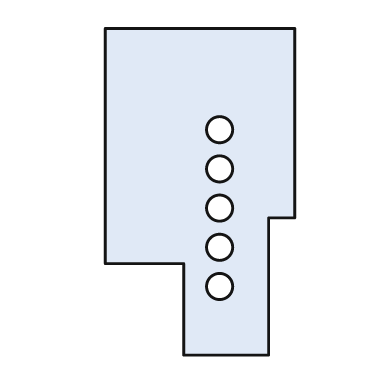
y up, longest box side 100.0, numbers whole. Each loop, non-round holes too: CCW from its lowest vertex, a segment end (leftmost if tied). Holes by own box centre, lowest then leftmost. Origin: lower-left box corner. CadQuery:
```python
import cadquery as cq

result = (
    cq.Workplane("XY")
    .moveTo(24.0, 0.0)
    .lineTo(50.0, 0.0)
    .lineTo(50.0, 42.0)
    .lineTo(58.0, 42.0)
    .lineTo(58.0, 100.0)
    .lineTo(0.0, 100.0)
    .lineTo(0.0, 28.0)
    .lineTo(24.0, 28.0)
    .close()
    .moveTo(35.0, 21.0)
    .circle(4.0)
    .moveTo(35.0, 33.0)
    .circle(4.0)
    .moveTo(35.0, 45.0)
    .circle(4.0)
    .moveTo(35.0, 57.0)
    .circle(4.0)
    .moveTo(35.0, 69.0)
    .circle(4.0)
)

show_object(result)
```